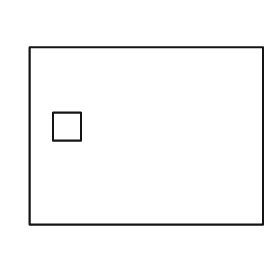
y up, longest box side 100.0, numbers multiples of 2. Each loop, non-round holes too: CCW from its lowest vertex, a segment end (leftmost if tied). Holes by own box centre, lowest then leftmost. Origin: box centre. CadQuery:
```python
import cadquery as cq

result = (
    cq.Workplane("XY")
    .moveTo(-50.0, -38.0)
    .lineTo(50.0, -38.0)
    .lineTo(50.0, 38.0)
    .lineTo(-50.0, 38.0)
    .close()
    .moveTo(-40.0, -2.0)
    .lineTo(-28.0, -2.0)
    .lineTo(-28.0, 10.0)
    .lineTo(-40.0, 10.0)
    .close()
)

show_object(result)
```